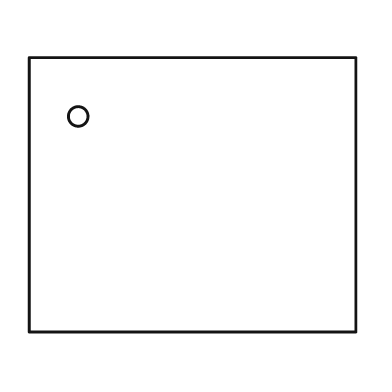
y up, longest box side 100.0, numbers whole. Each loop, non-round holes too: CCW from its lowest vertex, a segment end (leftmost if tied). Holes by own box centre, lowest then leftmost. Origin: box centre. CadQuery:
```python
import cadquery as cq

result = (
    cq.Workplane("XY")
    .moveTo(-50.0, -42.0)
    .lineTo(50.0, -42.0)
    .lineTo(50.0, 42.0)
    .lineTo(-50.0, 42.0)
    .close()
    .moveTo(-35.0, 24.0)
    .circle(3.0)
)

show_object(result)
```